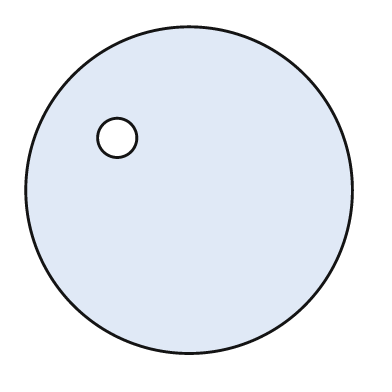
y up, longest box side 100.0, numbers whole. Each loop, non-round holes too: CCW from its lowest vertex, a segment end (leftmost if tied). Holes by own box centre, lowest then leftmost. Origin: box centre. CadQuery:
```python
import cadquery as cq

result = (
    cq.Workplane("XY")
    .moveTo(0.0, 0.0)
    .circle(50.0)
    .moveTo(-22.0, 16.0)
    .circle(6.0)
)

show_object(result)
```